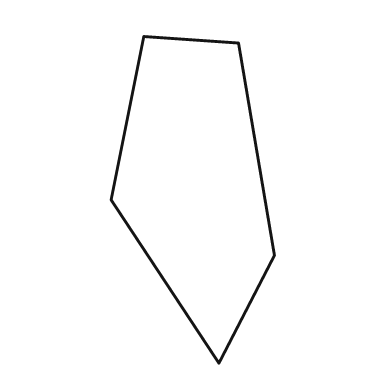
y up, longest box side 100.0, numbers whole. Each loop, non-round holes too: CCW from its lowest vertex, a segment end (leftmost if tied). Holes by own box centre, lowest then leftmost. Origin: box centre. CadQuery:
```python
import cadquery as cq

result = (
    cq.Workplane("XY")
    .moveTo(8.0, -50.0)
    .lineTo(25.0, -17.0)
    .lineTo(14.0, 48.0)
    .lineTo(-15.0, 50.0)
    .lineTo(-25.0, 0.0)
    .close()
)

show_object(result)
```